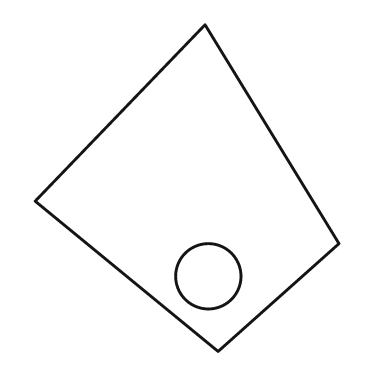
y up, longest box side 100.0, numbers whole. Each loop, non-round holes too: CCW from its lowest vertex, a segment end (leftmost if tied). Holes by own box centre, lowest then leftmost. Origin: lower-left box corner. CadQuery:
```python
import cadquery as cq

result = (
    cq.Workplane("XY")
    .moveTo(56.0, 0.0)
    .lineTo(93.0, 33.0)
    .lineTo(52.0, 100.0)
    .lineTo(0.0, 46.0)
    .close()
    .moveTo(53.0, 23.0)
    .circle(10.0)
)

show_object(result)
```